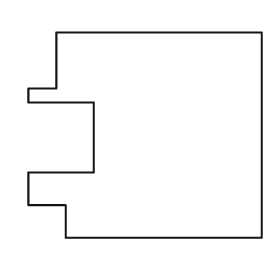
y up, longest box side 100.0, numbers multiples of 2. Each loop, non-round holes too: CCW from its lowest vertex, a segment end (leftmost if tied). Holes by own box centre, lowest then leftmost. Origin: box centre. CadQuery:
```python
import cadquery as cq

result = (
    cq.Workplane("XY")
    .moveTo(-34.0, -44.0)
    .lineTo(50.0, -44.0)
    .lineTo(50.0, 44.0)
    .lineTo(-38.0, 44.0)
    .lineTo(-38.0, 20.0)
    .lineTo(-50.0, 20.0)
    .lineTo(-50.0, 14.0)
    .lineTo(-22.0, 14.0)
    .lineTo(-22.0, -16.0)
    .lineTo(-50.0, -16.0)
    .lineTo(-50.0, -30.0)
    .lineTo(-34.0, -30.0)
    .close()
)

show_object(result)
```